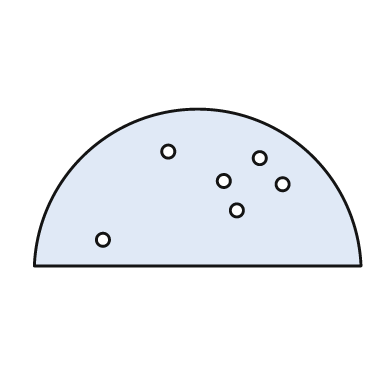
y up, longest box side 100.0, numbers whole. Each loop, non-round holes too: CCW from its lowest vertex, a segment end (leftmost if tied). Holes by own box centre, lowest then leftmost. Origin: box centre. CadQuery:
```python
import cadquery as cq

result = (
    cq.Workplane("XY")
    .moveTo(-50.0, -24.0)
    .lineTo(50.0, -24.0)
    .threePointArc((0.0, 24.0), (-50.0, -24.0))
    .close()
    .moveTo(-29.0, -16.0)
    .circle(2.0)
    .moveTo(12.0, -7.0)
    .circle(2.0)
    .moveTo(26.0, 1.0)
    .circle(2.0)
    .moveTo(8.0, 2.0)
    .circle(2.0)
    .moveTo(19.0, 9.0)
    .circle(2.0)
    .moveTo(-9.0, 11.0)
    .circle(2.0)
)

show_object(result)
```